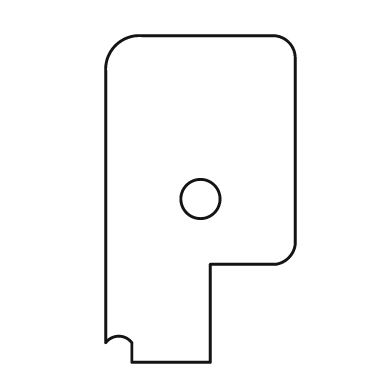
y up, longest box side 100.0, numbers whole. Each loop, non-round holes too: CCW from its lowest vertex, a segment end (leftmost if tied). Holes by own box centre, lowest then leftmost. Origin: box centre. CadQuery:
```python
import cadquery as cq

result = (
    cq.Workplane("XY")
    .moveTo(-21.0, -50.0)
    .lineTo(3.0, -50.0)
    .lineTo(3.0, -20.0)
    .lineTo(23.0, -20.0)
    .threePointArc((27.0, -18.0), (29.0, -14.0))
    .lineTo(29.0, 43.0)
    .threePointArc((27.0, 48.0), (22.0, 50.0))
    .lineTo(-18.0, 50.0)
    .threePointArc((-26.0, 47.0), (-29.0, 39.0))
    .lineTo(-29.0, -44.0)
    .threePointArc((-25.0, -42.0), (-21.0, -44.0))
    .close()
    .moveTo(0.0, 0.0)
    .circle(6.0)
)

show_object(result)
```